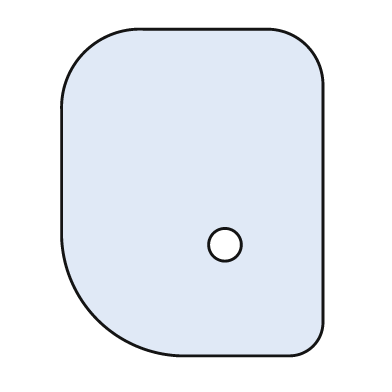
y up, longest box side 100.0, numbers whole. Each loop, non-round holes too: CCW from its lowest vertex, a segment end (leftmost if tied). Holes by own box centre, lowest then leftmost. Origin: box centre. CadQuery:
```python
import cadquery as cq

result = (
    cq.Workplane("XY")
    .moveTo(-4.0, -50.0)
    .lineTo(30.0, -50.0)
    .threePointArc((37.0, -47.0), (40.0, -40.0))
    .lineTo(40.0, 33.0)
    .threePointArc((35.0, 45.0), (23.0, 50.0))
    .lineTo(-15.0, 50.0)
    .threePointArc((-33.0, 43.0), (-40.0, 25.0))
    .lineTo(-40.0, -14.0)
    .threePointArc((-29.0, -39.0), (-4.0, -50.0))
    .close()
    .moveTo(10.0, -16.0)
    .circle(5.0)
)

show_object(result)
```